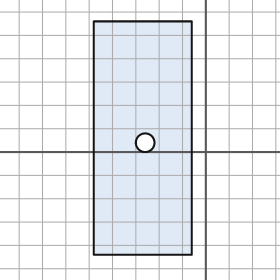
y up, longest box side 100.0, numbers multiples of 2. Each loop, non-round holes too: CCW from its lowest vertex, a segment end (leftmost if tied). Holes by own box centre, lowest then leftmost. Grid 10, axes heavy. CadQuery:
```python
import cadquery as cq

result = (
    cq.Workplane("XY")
    .moveTo(-48.0, -44.0)
    .lineTo(-6.0, -44.0)
    .lineTo(-6.0, 56.0)
    .lineTo(-48.0, 56.0)
    .close()
    .moveTo(-26.0, 4.0)
    .circle(4.0)
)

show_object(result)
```